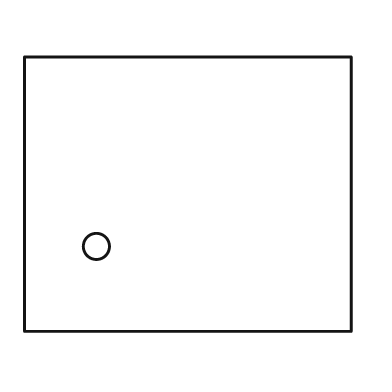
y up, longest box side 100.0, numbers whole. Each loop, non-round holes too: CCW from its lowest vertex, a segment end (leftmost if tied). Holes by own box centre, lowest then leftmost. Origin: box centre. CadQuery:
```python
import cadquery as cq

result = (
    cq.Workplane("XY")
    .moveTo(-50.0, -42.0)
    .lineTo(50.0, -42.0)
    .lineTo(50.0, 42.0)
    .lineTo(-50.0, 42.0)
    .close()
    .moveTo(-28.0, -16.0)
    .circle(4.0)
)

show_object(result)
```